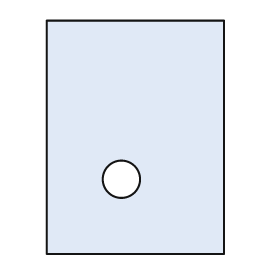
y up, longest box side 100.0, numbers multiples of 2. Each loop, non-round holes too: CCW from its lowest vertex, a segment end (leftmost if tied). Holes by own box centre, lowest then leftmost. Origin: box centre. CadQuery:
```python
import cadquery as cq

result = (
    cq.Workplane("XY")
    .moveTo(-38.0, -50.0)
    .lineTo(38.0, -50.0)
    .lineTo(38.0, 50.0)
    .lineTo(-38.0, 50.0)
    .close()
    .moveTo(-6.0, -18.0)
    .circle(8.0)
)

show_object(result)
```